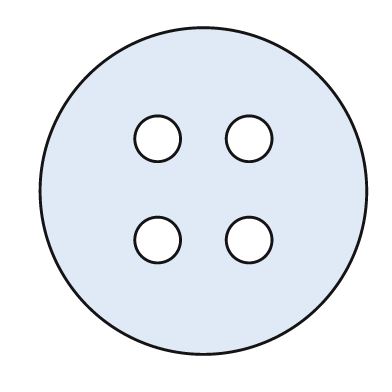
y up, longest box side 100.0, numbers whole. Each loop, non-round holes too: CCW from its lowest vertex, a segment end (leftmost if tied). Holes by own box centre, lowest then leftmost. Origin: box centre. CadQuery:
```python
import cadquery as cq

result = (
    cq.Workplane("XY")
    .moveTo(0.0, 0.0)
    .circle(50.0)
    .moveTo(-14.0, -15.0)
    .circle(7.0)
    .moveTo(14.0, -15.0)
    .circle(7.0)
    .moveTo(-14.0, 16.0)
    .circle(7.0)
    .moveTo(14.0, 16.0)
    .circle(7.0)
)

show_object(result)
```